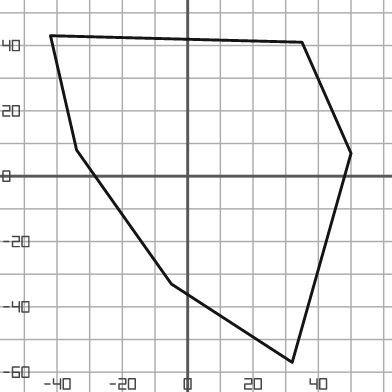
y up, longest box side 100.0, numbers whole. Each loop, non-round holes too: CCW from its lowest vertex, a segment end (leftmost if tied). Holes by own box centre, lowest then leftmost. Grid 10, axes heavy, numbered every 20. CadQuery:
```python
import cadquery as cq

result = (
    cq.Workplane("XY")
    .moveTo(32.0, -57.0)
    .lineTo(50.0, 7.0)
    .lineTo(35.0, 41.0)
    .lineTo(-42.0, 43.0)
    .lineTo(-34.0, 8.0)
    .lineTo(-5.0, -33.0)
    .close()
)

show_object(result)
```